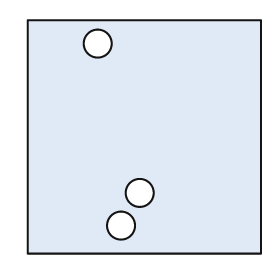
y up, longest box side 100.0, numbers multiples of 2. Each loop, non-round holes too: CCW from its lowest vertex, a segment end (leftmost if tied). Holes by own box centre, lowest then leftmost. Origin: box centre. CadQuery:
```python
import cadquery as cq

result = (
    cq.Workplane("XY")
    .moveTo(-50.0, -50.0)
    .lineTo(50.0, -50.0)
    .lineTo(50.0, 50.0)
    .lineTo(-50.0, 50.0)
    .close()
    .moveTo(-10.0, -38.0)
    .circle(6.0)
    .moveTo(-2.0, -24.0)
    .circle(6.0)
    .moveTo(-20.0, 40.0)
    .circle(6.0)
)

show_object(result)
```